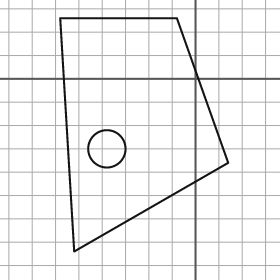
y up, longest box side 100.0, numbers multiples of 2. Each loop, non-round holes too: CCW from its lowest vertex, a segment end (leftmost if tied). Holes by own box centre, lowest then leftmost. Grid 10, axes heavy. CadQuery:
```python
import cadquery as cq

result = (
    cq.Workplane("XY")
    .moveTo(-52.0, -74.0)
    .lineTo(14.0, -36.0)
    .lineTo(-8.0, 26.0)
    .lineTo(-58.0, 26.0)
    .close()
    .moveTo(-38.0, -30.0)
    .circle(8.0)
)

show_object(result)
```